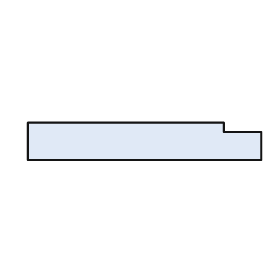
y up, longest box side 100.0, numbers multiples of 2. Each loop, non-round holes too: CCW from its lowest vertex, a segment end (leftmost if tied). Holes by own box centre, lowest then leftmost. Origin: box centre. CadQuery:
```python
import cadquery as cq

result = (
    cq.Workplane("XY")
    .moveTo(-50.0, -8.0)
    .lineTo(50.0, -8.0)
    .lineTo(50.0, 4.0)
    .lineTo(34.0, 4.0)
    .lineTo(34.0, 8.0)
    .lineTo(-50.0, 8.0)
    .close()
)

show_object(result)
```